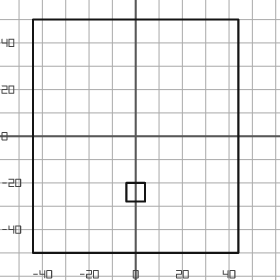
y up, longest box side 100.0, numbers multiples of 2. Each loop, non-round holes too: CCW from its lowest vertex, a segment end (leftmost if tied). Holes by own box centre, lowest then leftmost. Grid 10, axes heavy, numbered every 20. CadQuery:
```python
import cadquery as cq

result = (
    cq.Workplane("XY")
    .moveTo(-44.0, -50.0)
    .lineTo(44.0, -50.0)
    .lineTo(44.0, 50.0)
    .lineTo(-44.0, 50.0)
    .close()
    .moveTo(-4.0, -28.0)
    .lineTo(4.0, -28.0)
    .lineTo(4.0, -20.0)
    .lineTo(-4.0, -20.0)
    .close()
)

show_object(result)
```